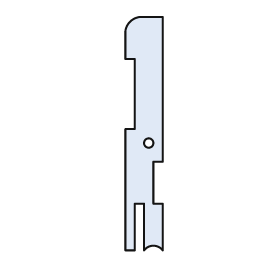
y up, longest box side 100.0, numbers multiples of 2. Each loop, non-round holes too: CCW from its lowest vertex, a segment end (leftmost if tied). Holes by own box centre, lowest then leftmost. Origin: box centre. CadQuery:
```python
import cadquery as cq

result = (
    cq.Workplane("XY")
    .moveTo(-8.0, -50.0)
    .lineTo(-4.0, -50.0)
    .lineTo(-4.0, -30.0)
    .lineTo(0.0, -30.0)
    .lineTo(0.0, -50.0)
    .threePointArc((4.0, -48.0), (8.0, -50.0))
    .lineTo(8.0, -30.0)
    .lineTo(4.0, -30.0)
    .lineTo(4.0, -12.0)
    .lineTo(8.0, -12.0)
    .lineTo(8.0, 50.0)
    .lineTo(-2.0, 50.0)
    .threePointArc((-6.0, 48.0), (-8.0, 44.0))
    .lineTo(-8.0, 32.0)
    .lineTo(-4.0, 32.0)
    .lineTo(-4.0, 2.0)
    .lineTo(-8.0, 2.0)
    .close()
    .moveTo(2.0, -4.0)
    .circle(2.0)
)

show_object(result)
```